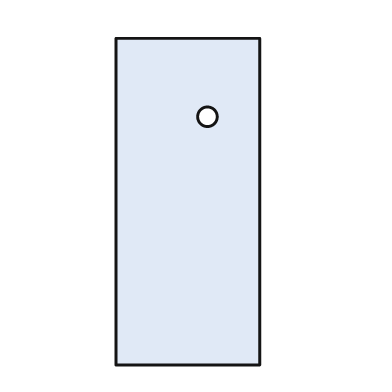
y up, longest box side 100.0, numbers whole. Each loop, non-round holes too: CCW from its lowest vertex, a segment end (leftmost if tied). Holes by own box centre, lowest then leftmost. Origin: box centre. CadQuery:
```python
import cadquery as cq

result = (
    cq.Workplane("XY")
    .moveTo(-22.0, -50.0)
    .lineTo(22.0, -50.0)
    .lineTo(22.0, 50.0)
    .lineTo(-22.0, 50.0)
    .close()
    .moveTo(6.0, 26.0)
    .circle(3.0)
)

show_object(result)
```